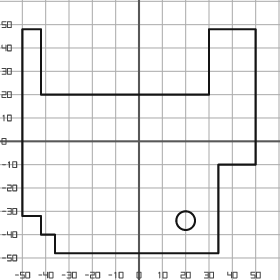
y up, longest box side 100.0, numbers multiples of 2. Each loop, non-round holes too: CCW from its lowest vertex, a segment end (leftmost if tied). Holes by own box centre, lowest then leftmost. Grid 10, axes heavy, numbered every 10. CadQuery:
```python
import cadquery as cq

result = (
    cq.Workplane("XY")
    .moveTo(-36.0, -48.0)
    .lineTo(34.0, -48.0)
    .lineTo(34.0, -10.0)
    .lineTo(50.0, -10.0)
    .lineTo(50.0, 48.0)
    .lineTo(30.0, 48.0)
    .lineTo(30.0, 20.0)
    .lineTo(-42.0, 20.0)
    .lineTo(-42.0, 48.0)
    .lineTo(-50.0, 48.0)
    .lineTo(-50.0, -32.0)
    .lineTo(-42.0, -32.0)
    .lineTo(-42.0, -40.0)
    .lineTo(-36.0, -40.0)
    .close()
    .moveTo(20.0, -34.0)
    .circle(4.0)
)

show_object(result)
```